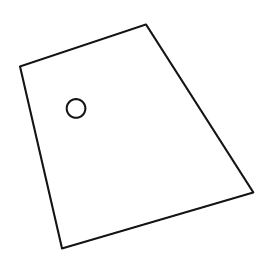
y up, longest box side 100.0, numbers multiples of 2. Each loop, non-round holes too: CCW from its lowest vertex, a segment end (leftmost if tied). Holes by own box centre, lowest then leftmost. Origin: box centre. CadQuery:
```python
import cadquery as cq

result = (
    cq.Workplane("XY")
    .moveTo(-32.0, -48.0)
    .lineTo(50.0, -24.0)
    .lineTo(4.0, 48.0)
    .lineTo(-50.0, 30.0)
    .close()
    .moveTo(-26.0, 12.0)
    .circle(4.0)
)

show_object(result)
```